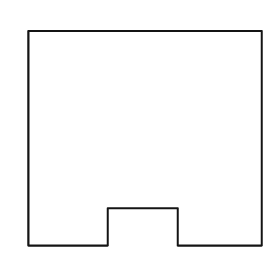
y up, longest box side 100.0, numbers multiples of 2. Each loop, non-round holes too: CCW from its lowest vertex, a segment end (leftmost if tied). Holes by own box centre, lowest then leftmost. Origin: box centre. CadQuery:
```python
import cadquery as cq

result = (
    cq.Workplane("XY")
    .moveTo(-50.0, -46.0)
    .lineTo(-16.0, -46.0)
    .lineTo(-16.0, -30.0)
    .lineTo(14.0, -30.0)
    .lineTo(14.0, -46.0)
    .lineTo(50.0, -46.0)
    .lineTo(50.0, 46.0)
    .lineTo(-50.0, 46.0)
    .close()
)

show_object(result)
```